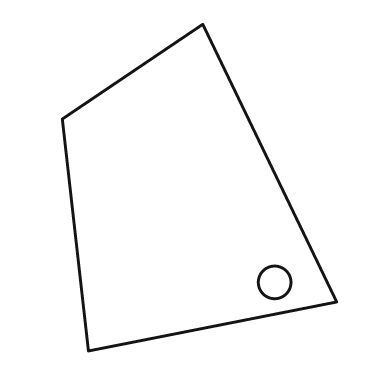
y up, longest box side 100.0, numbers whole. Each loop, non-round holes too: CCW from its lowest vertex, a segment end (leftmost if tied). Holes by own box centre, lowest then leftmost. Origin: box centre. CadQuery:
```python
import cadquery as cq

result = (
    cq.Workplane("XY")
    .moveTo(-34.0, -50.0)
    .lineTo(42.0, -35.0)
    .lineTo(1.0, 50.0)
    .lineTo(-42.0, 21.0)
    .close()
    .moveTo(23.0, -29.0)
    .circle(5.0)
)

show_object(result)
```